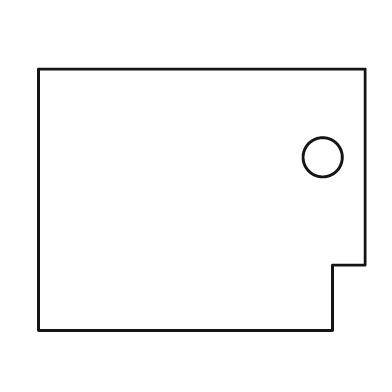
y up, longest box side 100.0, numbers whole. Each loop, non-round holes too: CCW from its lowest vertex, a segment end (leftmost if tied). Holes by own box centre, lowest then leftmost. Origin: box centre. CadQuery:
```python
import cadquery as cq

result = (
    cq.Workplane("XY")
    .moveTo(-50.0, -40.0)
    .lineTo(40.0, -40.0)
    .lineTo(40.0, -20.0)
    .lineTo(50.0, -20.0)
    .lineTo(50.0, 40.0)
    .lineTo(-50.0, 40.0)
    .close()
    .moveTo(37.0, 13.0)
    .circle(6.0)
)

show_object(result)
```